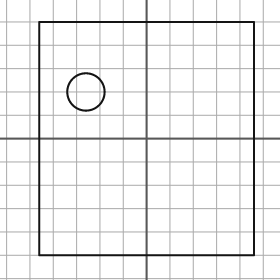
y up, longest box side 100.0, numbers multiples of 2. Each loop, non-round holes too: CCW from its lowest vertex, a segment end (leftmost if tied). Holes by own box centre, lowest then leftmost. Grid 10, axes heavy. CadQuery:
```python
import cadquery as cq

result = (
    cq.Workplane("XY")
    .moveTo(-46.0, -50.0)
    .lineTo(46.0, -50.0)
    .lineTo(46.0, 50.0)
    .lineTo(-46.0, 50.0)
    .close()
    .moveTo(-26.0, 20.0)
    .circle(8.0)
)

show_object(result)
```